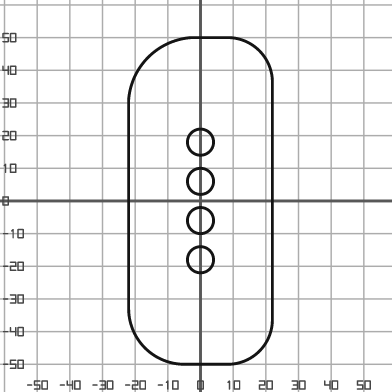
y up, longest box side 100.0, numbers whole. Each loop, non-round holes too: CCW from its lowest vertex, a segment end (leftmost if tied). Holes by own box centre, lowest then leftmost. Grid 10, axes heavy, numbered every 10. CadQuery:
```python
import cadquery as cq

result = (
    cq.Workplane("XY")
    .moveTo(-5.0, -50.0)
    .lineTo(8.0, -50.0)
    .threePointArc((18.0, -46.0), (22.0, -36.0))
    .lineTo(22.0, 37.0)
    .threePointArc((18.0, 46.0), (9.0, 50.0))
    .lineTo(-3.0, 50.0)
    .threePointArc((-16.0, 44.0), (-22.0, 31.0))
    .lineTo(-22.0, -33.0)
    .threePointArc((-17.0, -45.0), (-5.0, -50.0))
    .close()
    .moveTo(0.0, -18.0)
    .circle(4.0)
    .moveTo(0.0, -6.0)
    .circle(4.0)
    .moveTo(0.0, 6.0)
    .circle(4.0)
    .moveTo(0.0, 18.0)
    .circle(4.0)
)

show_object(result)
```